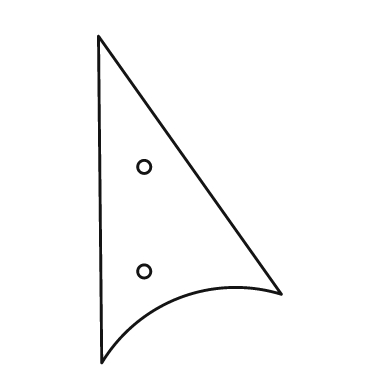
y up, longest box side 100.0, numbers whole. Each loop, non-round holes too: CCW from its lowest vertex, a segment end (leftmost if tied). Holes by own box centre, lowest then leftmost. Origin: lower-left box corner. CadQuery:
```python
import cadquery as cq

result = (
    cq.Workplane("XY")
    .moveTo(1.0, 0.0)
    .threePointArc((25.0, 20.0), (56.0, 21.0))
    .lineTo(0.0, 100.0)
    .close()
    .moveTo(14.0, 28.0)
    .circle(2.0)
    .moveTo(14.0, 60.0)
    .circle(2.0)
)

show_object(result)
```